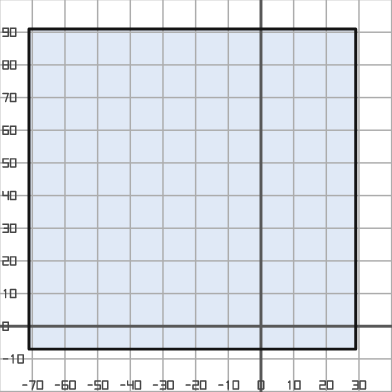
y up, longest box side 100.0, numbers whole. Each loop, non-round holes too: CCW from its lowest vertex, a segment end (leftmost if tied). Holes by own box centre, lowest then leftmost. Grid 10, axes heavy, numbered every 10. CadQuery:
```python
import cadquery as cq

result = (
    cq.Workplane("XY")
    .moveTo(-71.0, -7.0)
    .lineTo(29.0, -7.0)
    .lineTo(29.0, 91.0)
    .lineTo(-71.0, 91.0)
    .close()
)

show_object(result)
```